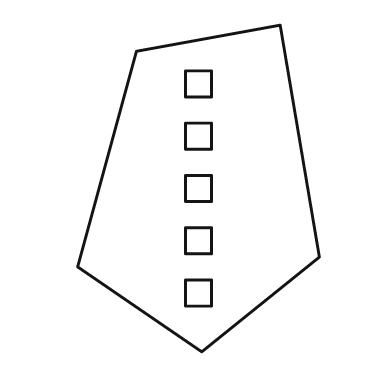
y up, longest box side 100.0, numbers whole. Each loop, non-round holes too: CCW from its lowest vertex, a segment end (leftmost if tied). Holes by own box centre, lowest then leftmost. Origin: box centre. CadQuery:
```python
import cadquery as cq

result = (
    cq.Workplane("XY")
    .moveTo(1.0, -50.0)
    .lineTo(37.0, -21.0)
    .lineTo(25.0, 50.0)
    .lineTo(-19.0, 42.0)
    .lineTo(-37.0, -24.0)
    .close()
    .moveTo(-4.0, -36.0)
    .lineTo(4.0, -36.0)
    .lineTo(4.0, -28.0)
    .lineTo(-4.0, -28.0)
    .close()
    .moveTo(-4.0, -20.0)
    .lineTo(4.0, -20.0)
    .lineTo(4.0, -12.0)
    .lineTo(-4.0, -12.0)
    .close()
    .moveTo(-4.0, -4.0)
    .lineTo(4.0, -4.0)
    .lineTo(4.0, 4.0)
    .lineTo(-4.0, 4.0)
    .close()
    .moveTo(-4.0, 12.0)
    .lineTo(4.0, 12.0)
    .lineTo(4.0, 20.0)
    .lineTo(-4.0, 20.0)
    .close()
    .moveTo(-4.0, 28.0)
    .lineTo(4.0, 28.0)
    .lineTo(4.0, 36.0)
    .lineTo(-4.0, 36.0)
    .close()
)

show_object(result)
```